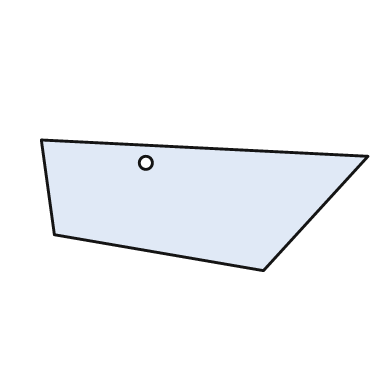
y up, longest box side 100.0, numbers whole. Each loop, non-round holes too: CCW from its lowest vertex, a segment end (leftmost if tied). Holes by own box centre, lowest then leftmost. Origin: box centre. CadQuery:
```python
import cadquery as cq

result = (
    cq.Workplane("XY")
    .moveTo(18.0, -20.0)
    .lineTo(50.0, 15.0)
    .lineTo(-50.0, 20.0)
    .lineTo(-46.0, -9.0)
    .close()
    .moveTo(-18.0, 13.0)
    .circle(2.0)
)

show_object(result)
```